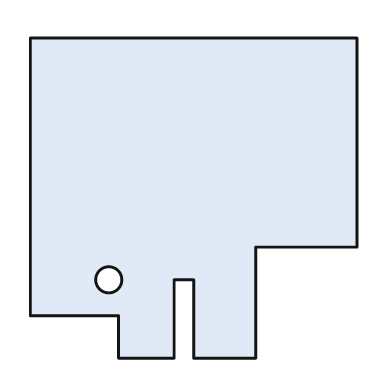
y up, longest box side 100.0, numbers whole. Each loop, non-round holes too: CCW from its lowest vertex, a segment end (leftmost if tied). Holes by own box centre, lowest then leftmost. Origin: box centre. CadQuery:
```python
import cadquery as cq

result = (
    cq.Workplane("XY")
    .moveTo(-23.0, -49.0)
    .lineTo(-6.0, -49.0)
    .lineTo(-6.0, -25.0)
    .lineTo(0.0, -25.0)
    .lineTo(0.0, -49.0)
    .lineTo(19.0, -49.0)
    .lineTo(19.0, -15.0)
    .lineTo(50.0, -15.0)
    .lineTo(50.0, 49.0)
    .lineTo(-50.0, 49.0)
    .lineTo(-50.0, -36.0)
    .lineTo(-23.0, -36.0)
    .close()
    .moveTo(-26.0, -25.0)
    .circle(4.0)
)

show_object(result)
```